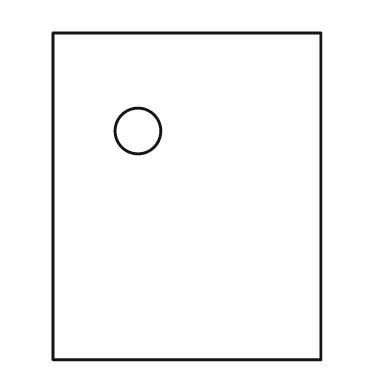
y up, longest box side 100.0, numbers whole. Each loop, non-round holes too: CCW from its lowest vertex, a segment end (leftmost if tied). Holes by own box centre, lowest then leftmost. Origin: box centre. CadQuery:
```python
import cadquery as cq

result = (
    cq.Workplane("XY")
    .moveTo(-41.0, -50.0)
    .lineTo(41.0, -50.0)
    .lineTo(41.0, 50.0)
    .lineTo(-41.0, 50.0)
    .close()
    .moveTo(-15.0, 20.0)
    .circle(7.0)
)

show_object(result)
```